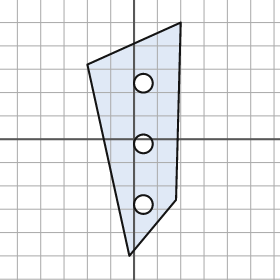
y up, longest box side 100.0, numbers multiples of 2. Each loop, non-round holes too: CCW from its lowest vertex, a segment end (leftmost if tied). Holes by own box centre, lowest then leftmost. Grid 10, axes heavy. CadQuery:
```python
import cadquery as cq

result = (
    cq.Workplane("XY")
    .moveTo(-2.0, -50.0)
    .lineTo(18.0, -26.0)
    .lineTo(20.0, 50.0)
    .lineTo(-20.0, 32.0)
    .close()
    .moveTo(4.0, -28.0)
    .circle(4.0)
    .moveTo(4.0, -2.0)
    .circle(4.0)
    .moveTo(4.0, 24.0)
    .circle(4.0)
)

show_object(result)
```